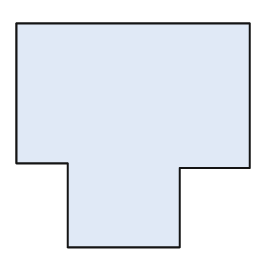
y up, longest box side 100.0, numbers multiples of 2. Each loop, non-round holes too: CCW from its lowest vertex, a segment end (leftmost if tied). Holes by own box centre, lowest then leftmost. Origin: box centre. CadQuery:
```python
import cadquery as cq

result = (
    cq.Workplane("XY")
    .moveTo(-28.0, -48.0)
    .lineTo(20.0, -48.0)
    .lineTo(20.0, -14.0)
    .lineTo(50.0, -14.0)
    .lineTo(50.0, 48.0)
    .lineTo(-50.0, 48.0)
    .lineTo(-50.0, -12.0)
    .lineTo(-28.0, -12.0)
    .close()
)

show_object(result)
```